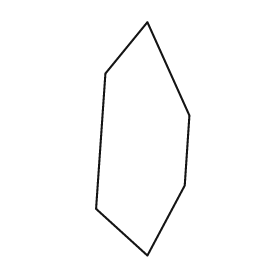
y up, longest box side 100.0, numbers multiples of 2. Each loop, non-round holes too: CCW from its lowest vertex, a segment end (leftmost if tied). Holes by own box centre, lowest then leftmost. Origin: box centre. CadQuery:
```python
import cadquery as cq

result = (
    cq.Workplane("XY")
    .moveTo(2.0, -50.0)
    .lineTo(18.0, -20.0)
    .lineTo(20.0, 10.0)
    .lineTo(2.0, 50.0)
    .lineTo(-16.0, 28.0)
    .lineTo(-20.0, -30.0)
    .close()
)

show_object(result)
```